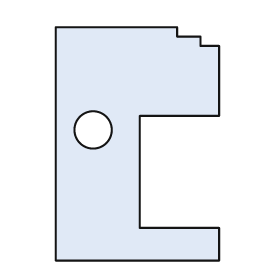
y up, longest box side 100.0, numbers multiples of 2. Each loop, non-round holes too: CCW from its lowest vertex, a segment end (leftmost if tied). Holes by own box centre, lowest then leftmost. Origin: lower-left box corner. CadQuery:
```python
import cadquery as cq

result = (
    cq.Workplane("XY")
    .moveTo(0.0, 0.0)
    .lineTo(70.0, 0.0)
    .lineTo(70.0, 14.0)
    .lineTo(36.0, 14.0)
    .lineTo(36.0, 62.0)
    .lineTo(70.0, 62.0)
    .lineTo(70.0, 92.0)
    .lineTo(62.0, 92.0)
    .lineTo(62.0, 96.0)
    .lineTo(52.0, 96.0)
    .lineTo(52.0, 100.0)
    .lineTo(0.0, 100.0)
    .close()
    .moveTo(16.0, 56.0)
    .circle(8.0)
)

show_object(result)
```